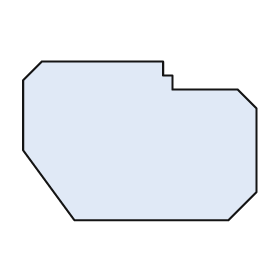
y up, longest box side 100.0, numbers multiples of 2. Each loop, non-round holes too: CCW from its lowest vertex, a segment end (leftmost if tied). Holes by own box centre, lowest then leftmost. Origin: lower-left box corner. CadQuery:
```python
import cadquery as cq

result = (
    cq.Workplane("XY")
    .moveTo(22.0, 0.0)
    .lineTo(88.0, 0.0)
    .lineTo(100.0, 12.0)
    .lineTo(100.0, 48.0)
    .lineTo(92.0, 56.0)
    .lineTo(64.0, 56.0)
    .lineTo(64.0, 62.0)
    .lineTo(60.0, 62.0)
    .lineTo(60.0, 68.0)
    .lineTo(8.0, 68.0)
    .lineTo(0.0, 60.0)
    .lineTo(0.0, 30.0)
    .close()
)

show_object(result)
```